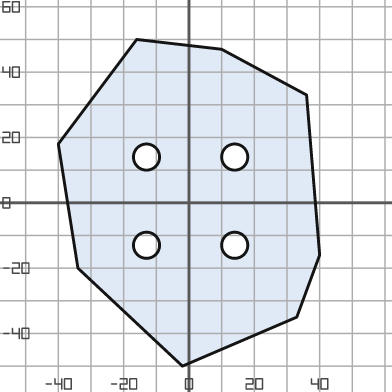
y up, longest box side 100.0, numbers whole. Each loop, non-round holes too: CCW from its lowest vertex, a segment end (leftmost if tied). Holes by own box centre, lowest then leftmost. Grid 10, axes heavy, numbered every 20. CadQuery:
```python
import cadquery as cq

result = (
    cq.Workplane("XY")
    .moveTo(-2.0, -50.0)
    .lineTo(33.0, -35.0)
    .lineTo(40.0, -16.0)
    .lineTo(36.0, 33.0)
    .lineTo(10.0, 47.0)
    .lineTo(-16.0, 50.0)
    .lineTo(-40.0, 18.0)
    .lineTo(-34.0, -20.0)
    .close()
    .moveTo(-13.0, -13.0)
    .circle(4.0)
    .moveTo(14.0, -13.0)
    .circle(4.0)
    .moveTo(-13.0, 14.0)
    .circle(4.0)
    .moveTo(14.0, 14.0)
    .circle(4.0)
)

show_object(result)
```